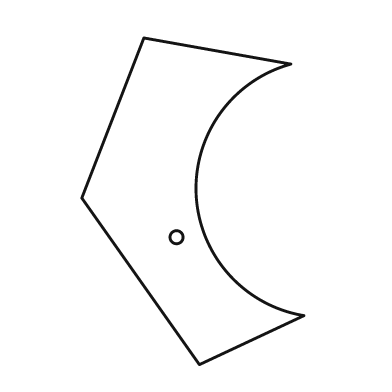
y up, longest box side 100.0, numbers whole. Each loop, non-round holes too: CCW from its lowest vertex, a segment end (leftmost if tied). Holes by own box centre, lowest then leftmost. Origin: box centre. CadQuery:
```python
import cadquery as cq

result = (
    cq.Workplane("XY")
    .moveTo(2.0, -50.0)
    .lineTo(34.0, -35.0)
    .threePointArc((1.0, 2.0), (30.0, 42.0))
    .lineTo(-15.0, 50.0)
    .lineTo(-34.0, 1.0)
    .close()
    .moveTo(-5.0, -11.0)
    .circle(2.0)
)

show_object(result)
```